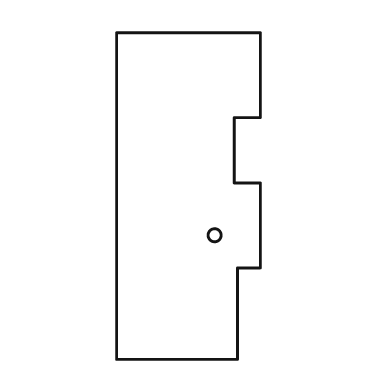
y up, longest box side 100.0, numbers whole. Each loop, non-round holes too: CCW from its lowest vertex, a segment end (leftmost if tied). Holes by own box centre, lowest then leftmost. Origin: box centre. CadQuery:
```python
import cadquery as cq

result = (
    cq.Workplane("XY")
    .moveTo(-22.0, -50.0)
    .lineTo(15.0, -50.0)
    .lineTo(15.0, -22.0)
    .lineTo(22.0, -22.0)
    .lineTo(22.0, 4.0)
    .lineTo(14.0, 4.0)
    .lineTo(14.0, 24.0)
    .lineTo(22.0, 24.0)
    .lineTo(22.0, 50.0)
    .lineTo(-22.0, 50.0)
    .close()
    .moveTo(8.0, -12.0)
    .circle(2.0)
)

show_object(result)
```